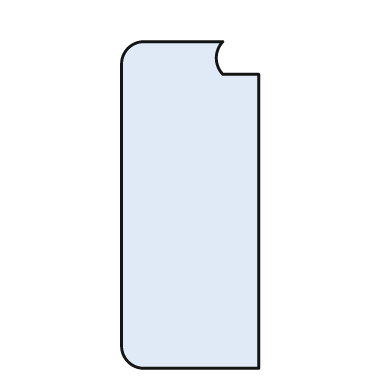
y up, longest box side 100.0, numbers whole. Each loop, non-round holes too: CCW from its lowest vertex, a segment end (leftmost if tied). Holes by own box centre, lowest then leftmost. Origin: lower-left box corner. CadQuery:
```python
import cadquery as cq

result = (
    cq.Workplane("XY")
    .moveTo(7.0, 0.0)
    .lineTo(42.0, 0.0)
    .lineTo(42.0, 90.0)
    .lineTo(31.0, 90.0)
    .threePointArc((29.0, 95.0), (31.0, 100.0))
    .lineTo(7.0, 100.0)
    .threePointArc((2.0, 98.0), (0.0, 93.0))
    .lineTo(0.0, 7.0)
    .threePointArc((2.0, 2.0), (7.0, 0.0))
    .close()
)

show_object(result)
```